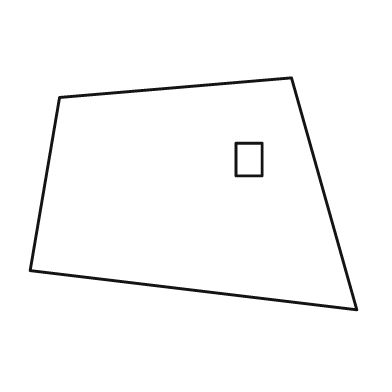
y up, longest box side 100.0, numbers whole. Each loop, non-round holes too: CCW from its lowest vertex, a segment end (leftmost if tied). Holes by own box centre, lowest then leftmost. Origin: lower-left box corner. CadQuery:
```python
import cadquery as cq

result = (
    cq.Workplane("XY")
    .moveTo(100.0, 0.0)
    .lineTo(80.0, 71.0)
    .lineTo(9.0, 65.0)
    .lineTo(0.0, 12.0)
    .close()
    .moveTo(63.0, 41.0)
    .lineTo(71.0, 41.0)
    .lineTo(71.0, 51.0)
    .lineTo(63.0, 51.0)
    .close()
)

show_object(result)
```